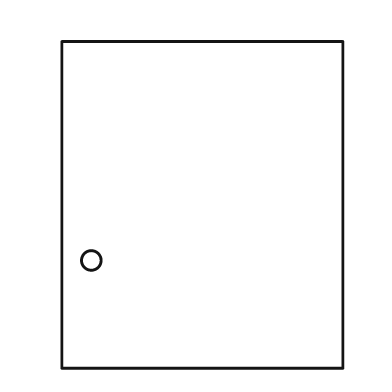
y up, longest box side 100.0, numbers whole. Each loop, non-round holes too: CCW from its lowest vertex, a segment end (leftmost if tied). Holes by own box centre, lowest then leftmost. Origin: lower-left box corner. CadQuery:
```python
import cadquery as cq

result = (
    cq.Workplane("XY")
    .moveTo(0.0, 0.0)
    .lineTo(86.0, 0.0)
    .lineTo(86.0, 100.0)
    .lineTo(0.0, 100.0)
    .close()
    .moveTo(9.0, 33.0)
    .circle(3.0)
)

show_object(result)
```